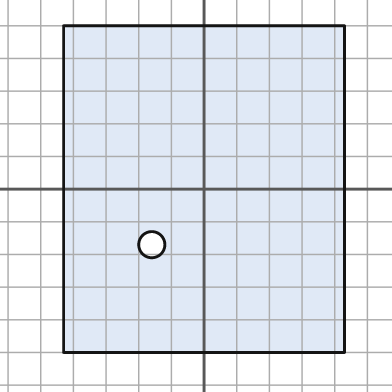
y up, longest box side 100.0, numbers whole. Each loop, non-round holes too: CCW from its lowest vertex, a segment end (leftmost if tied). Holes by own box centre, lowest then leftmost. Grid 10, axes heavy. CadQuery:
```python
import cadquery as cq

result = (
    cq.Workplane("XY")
    .moveTo(-43.0, -50.0)
    .lineTo(43.0, -50.0)
    .lineTo(43.0, 50.0)
    .lineTo(-43.0, 50.0)
    .close()
    .moveTo(-16.0, -17.0)
    .circle(4.0)
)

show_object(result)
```